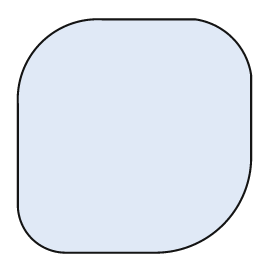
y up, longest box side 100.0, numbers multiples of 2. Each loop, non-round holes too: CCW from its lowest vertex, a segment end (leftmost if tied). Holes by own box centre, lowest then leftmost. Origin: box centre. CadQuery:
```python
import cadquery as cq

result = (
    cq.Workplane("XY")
    .moveTo(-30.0, -50.0)
    .lineTo(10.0, -50.0)
    .threePointArc((38.0, -38.0), (50.0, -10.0))
    .lineTo(50.0, 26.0)
    .threePointArc((42.0, 42.0), (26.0, 50.0))
    .lineTo(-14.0, 50.0)
    .threePointArc((-40.0, 40.0), (-50.0, 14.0))
    .lineTo(-50.0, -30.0)
    .threePointArc((-44.0, -44.0), (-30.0, -50.0))
    .close()
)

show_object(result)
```